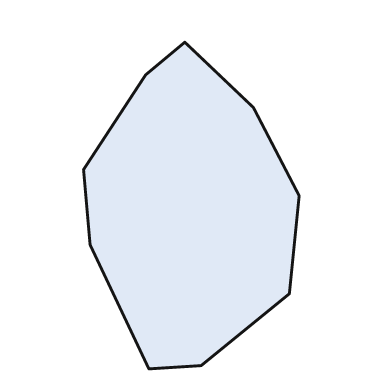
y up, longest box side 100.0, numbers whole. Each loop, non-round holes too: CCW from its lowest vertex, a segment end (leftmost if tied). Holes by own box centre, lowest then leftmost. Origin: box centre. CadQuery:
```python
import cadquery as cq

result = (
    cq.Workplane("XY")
    .moveTo(-13.0, -50.0)
    .lineTo(3.0, -49.0)
    .lineTo(30.0, -27.0)
    .lineTo(33.0, 3.0)
    .lineTo(19.0, 30.0)
    .lineTo(-2.0, 50.0)
    .lineTo(-14.0, 40.0)
    .lineTo(-33.0, 11.0)
    .lineTo(-31.0, -12.0)
    .close()
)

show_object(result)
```